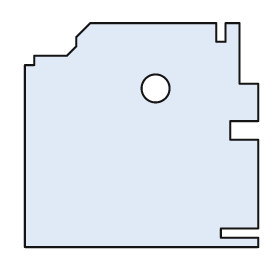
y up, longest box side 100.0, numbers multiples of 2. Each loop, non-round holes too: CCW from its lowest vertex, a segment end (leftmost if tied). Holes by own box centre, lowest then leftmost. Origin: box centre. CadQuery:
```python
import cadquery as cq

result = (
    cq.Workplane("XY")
    .moveTo(-50.0, -48.0)
    .lineTo(50.0, -48.0)
    .lineTo(50.0, -44.0)
    .lineTo(34.0, -44.0)
    .lineTo(34.0, -40.0)
    .lineTo(50.0, -40.0)
    .lineTo(50.0, -2.0)
    .lineTo(38.0, -2.0)
    .lineTo(38.0, 6.0)
    .lineTo(50.0, 6.0)
    .lineTo(50.0, 22.0)
    .lineTo(42.0, 22.0)
    .lineTo(42.0, 48.0)
    .lineTo(36.0, 48.0)
    .lineTo(36.0, 40.0)
    .lineTo(32.0, 40.0)
    .lineTo(32.0, 48.0)
    .lineTo(-22.0, 48.0)
    .lineTo(-28.0, 42.0)
    .lineTo(-28.0, 38.0)
    .lineTo(-32.0, 34.0)
    .lineTo(-46.0, 34.0)
    .lineTo(-46.0, 30.0)
    .lineTo(-50.0, 30.0)
    .close()
    .moveTo(6.0, 20.0)
    .circle(6.0)
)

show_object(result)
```